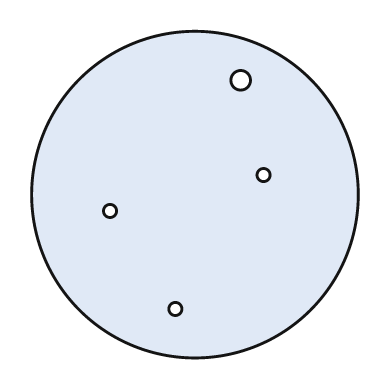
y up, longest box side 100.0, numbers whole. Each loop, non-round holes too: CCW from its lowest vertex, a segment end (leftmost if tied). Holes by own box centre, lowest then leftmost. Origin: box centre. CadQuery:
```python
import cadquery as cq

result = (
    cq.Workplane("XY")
    .moveTo(0.0, 0.0)
    .circle(50.0)
    .moveTo(-6.0, -35.0)
    .circle(2.0)
    .moveTo(-26.0, -5.0)
    .circle(2.0)
    .moveTo(21.0, 6.0)
    .circle(2.0)
    .moveTo(14.0, 35.0)
    .circle(3.0)
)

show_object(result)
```